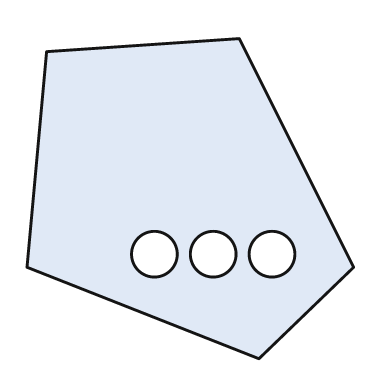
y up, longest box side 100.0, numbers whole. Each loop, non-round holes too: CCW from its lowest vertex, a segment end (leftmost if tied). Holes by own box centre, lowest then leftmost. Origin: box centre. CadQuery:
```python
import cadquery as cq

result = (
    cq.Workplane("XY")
    .moveTo(21.0, -49.0)
    .lineTo(50.0, -21.0)
    .lineTo(15.0, 49.0)
    .lineTo(-44.0, 45.0)
    .lineTo(-50.0, -21.0)
    .close()
    .moveTo(-11.0, -17.0)
    .circle(7.0)
    .moveTo(7.0, -17.0)
    .circle(7.0)
    .moveTo(25.0, -17.0)
    .circle(7.0)
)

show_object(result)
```